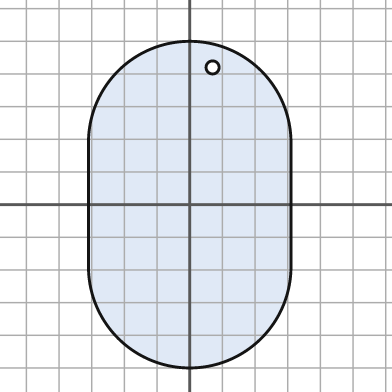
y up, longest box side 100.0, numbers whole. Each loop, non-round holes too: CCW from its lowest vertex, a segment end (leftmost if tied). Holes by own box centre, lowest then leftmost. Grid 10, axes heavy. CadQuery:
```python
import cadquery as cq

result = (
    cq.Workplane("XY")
    .moveTo(-31.0, -19.0)
    .threePointArc((0.0, -50.0), (31.0, -19.0))
    .lineTo(31.0, 19.0)
    .threePointArc((0.0, 50.0), (-31.0, 19.0))
    .close()
    .moveTo(7.0, 42.0)
    .circle(2.0)
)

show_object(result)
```